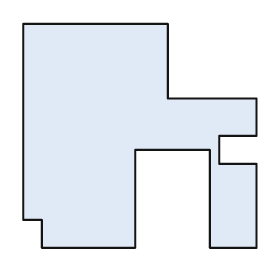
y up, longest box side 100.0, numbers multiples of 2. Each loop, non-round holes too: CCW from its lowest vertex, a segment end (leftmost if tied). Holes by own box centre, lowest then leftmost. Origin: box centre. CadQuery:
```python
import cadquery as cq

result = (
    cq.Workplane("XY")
    .moveTo(-42.0, -48.0)
    .lineTo(-2.0, -48.0)
    .lineTo(-2.0, -6.0)
    .lineTo(30.0, -6.0)
    .lineTo(30.0, -48.0)
    .lineTo(50.0, -48.0)
    .lineTo(50.0, -12.0)
    .lineTo(34.0, -12.0)
    .lineTo(34.0, 0.0)
    .lineTo(50.0, 0.0)
    .lineTo(50.0, 16.0)
    .lineTo(12.0, 16.0)
    .lineTo(12.0, 48.0)
    .lineTo(-50.0, 48.0)
    .lineTo(-50.0, -36.0)
    .lineTo(-42.0, -36.0)
    .close()
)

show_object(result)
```